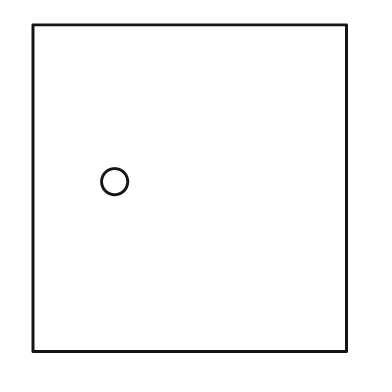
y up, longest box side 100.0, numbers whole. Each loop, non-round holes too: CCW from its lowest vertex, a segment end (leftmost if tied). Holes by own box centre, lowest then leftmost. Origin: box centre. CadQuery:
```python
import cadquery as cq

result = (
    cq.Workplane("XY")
    .moveTo(-48.0, -50.0)
    .lineTo(48.0, -50.0)
    .lineTo(48.0, 50.0)
    .lineTo(-48.0, 50.0)
    .close()
    .moveTo(-23.0, 2.0)
    .circle(4.0)
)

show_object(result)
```